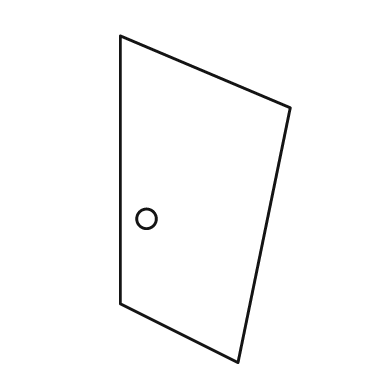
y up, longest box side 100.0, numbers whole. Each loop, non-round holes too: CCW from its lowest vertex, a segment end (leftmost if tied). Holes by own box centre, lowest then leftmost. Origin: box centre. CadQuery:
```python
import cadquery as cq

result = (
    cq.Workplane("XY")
    .moveTo(10.0, -50.0)
    .lineTo(26.0, 28.0)
    .lineTo(-26.0, 50.0)
    .lineTo(-26.0, -32.0)
    .close()
    .moveTo(-18.0, -6.0)
    .circle(3.0)
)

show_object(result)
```